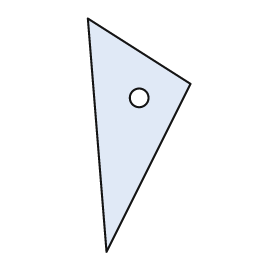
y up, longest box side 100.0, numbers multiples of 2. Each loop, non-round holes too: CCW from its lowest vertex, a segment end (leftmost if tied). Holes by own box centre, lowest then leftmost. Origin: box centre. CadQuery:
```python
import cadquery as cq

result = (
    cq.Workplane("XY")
    .moveTo(-14.0, -50.0)
    .lineTo(22.0, 22.0)
    .lineTo(-22.0, 50.0)
    .close()
    .moveTo(0.0, 16.0)
    .circle(4.0)
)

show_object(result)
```